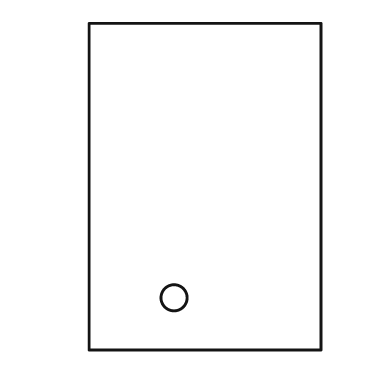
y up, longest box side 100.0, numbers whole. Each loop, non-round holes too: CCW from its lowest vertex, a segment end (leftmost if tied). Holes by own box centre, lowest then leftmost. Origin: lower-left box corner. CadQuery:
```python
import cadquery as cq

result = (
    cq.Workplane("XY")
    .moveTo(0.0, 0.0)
    .lineTo(71.0, 0.0)
    .lineTo(71.0, 100.0)
    .lineTo(0.0, 100.0)
    .close()
    .moveTo(26.0, 16.0)
    .circle(4.0)
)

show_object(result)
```